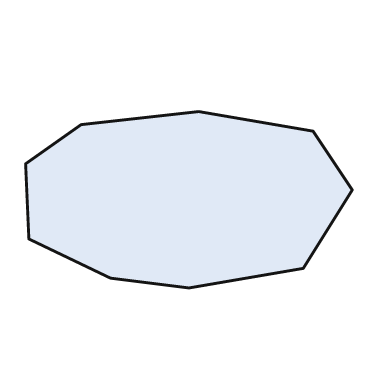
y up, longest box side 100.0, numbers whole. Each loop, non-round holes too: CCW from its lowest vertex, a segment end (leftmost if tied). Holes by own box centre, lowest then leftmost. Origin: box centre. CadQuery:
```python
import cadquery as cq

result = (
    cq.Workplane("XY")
    .moveTo(0.0, -27.0)
    .lineTo(35.0, -21.0)
    .lineTo(50.0, 3.0)
    .lineTo(38.0, 21.0)
    .lineTo(3.0, 27.0)
    .lineTo(-33.0, 23.0)
    .lineTo(-50.0, 11.0)
    .lineTo(-49.0, -12.0)
    .lineTo(-24.0, -24.0)
    .close()
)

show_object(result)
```